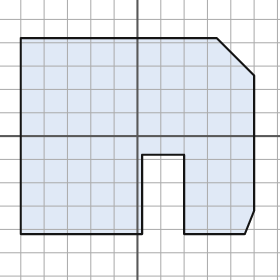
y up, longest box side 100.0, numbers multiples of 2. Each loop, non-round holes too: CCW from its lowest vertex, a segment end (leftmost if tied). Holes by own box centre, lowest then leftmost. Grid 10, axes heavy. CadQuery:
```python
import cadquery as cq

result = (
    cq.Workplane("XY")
    .moveTo(-50.0, -42.0)
    .lineTo(2.0, -42.0)
    .lineTo(2.0, -8.0)
    .lineTo(20.0, -8.0)
    .lineTo(20.0, -42.0)
    .lineTo(46.0, -42.0)
    .lineTo(50.0, -32.0)
    .lineTo(50.0, 26.0)
    .lineTo(34.0, 42.0)
    .lineTo(-50.0, 42.0)
    .close()
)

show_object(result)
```